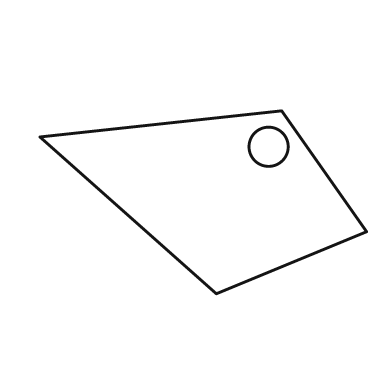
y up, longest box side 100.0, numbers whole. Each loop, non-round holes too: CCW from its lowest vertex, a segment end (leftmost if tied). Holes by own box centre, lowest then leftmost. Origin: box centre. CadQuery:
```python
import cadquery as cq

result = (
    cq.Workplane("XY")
    .moveTo(4.0, -28.0)
    .lineTo(50.0, -9.0)
    .lineTo(24.0, 28.0)
    .lineTo(-50.0, 20.0)
    .close()
    .moveTo(20.0, 17.0)
    .circle(6.0)
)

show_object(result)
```